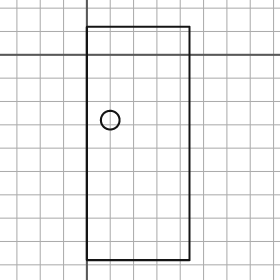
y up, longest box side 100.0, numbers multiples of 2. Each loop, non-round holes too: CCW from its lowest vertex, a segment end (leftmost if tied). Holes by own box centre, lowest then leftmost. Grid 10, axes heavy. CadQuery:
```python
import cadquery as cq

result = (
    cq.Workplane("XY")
    .moveTo(0.0, -88.0)
    .lineTo(44.0, -88.0)
    .lineTo(44.0, 12.0)
    .lineTo(0.0, 12.0)
    .close()
    .moveTo(10.0, -28.0)
    .circle(4.0)
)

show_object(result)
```